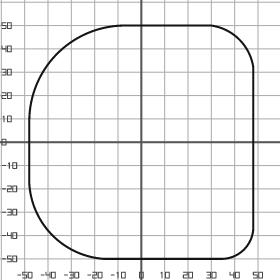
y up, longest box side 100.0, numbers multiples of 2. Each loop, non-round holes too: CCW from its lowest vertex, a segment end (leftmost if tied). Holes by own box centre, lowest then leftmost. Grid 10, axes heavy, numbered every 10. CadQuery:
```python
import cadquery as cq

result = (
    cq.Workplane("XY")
    .moveTo(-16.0, -50.0)
    .lineTo(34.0, -50.0)
    .threePointArc((44.0, -46.0), (48.0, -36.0))
    .lineTo(48.0, 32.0)
    .threePointArc((42.0, 44.0), (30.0, 50.0))
    .lineTo(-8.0, 50.0)
    .threePointArc((-36.0, 38.0), (-48.0, 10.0))
    .lineTo(-48.0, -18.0)
    .threePointArc((-38.0, -40.0), (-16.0, -50.0))
    .close()
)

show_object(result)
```